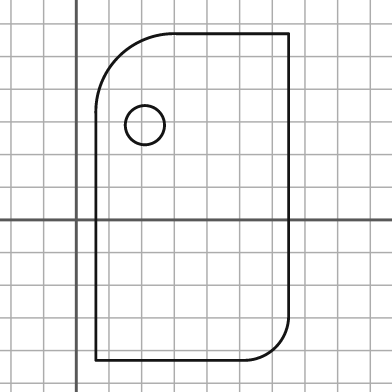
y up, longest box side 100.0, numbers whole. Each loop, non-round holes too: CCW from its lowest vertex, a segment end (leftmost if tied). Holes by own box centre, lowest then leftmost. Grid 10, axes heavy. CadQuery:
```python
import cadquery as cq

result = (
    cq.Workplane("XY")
    .moveTo(6.0, -43.0)
    .lineTo(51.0, -43.0)
    .threePointArc((61.0, -39.0), (65.0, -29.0))
    .lineTo(65.0, 57.0)
    .lineTo(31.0, 57.0)
    .threePointArc((13.0, 50.0), (6.0, 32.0))
    .close()
    .moveTo(21.0, 29.0)
    .circle(6.0)
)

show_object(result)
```